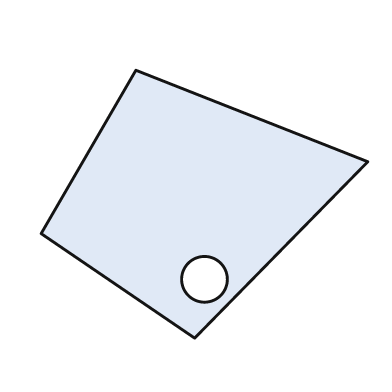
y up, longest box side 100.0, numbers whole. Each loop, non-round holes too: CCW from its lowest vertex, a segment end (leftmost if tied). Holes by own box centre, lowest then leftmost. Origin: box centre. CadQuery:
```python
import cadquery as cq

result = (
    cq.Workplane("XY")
    .moveTo(-3.0, -41.0)
    .lineTo(50.0, 13.0)
    .lineTo(-21.0, 41.0)
    .lineTo(-50.0, -9.0)
    .close()
    .moveTo(0.0, -23.0)
    .circle(7.0)
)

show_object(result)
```